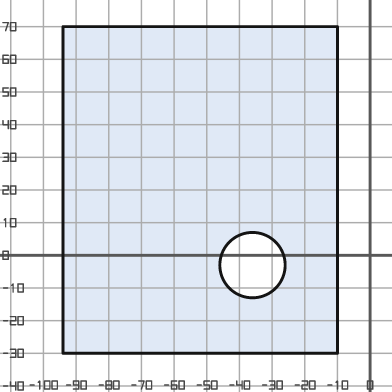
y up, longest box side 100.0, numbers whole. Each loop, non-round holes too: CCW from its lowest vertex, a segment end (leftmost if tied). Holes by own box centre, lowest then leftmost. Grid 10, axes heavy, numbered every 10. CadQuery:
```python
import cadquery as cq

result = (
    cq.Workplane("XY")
    .moveTo(-94.0, -30.0)
    .lineTo(-10.0, -30.0)
    .lineTo(-10.0, 70.0)
    .lineTo(-94.0, 70.0)
    .close()
    .moveTo(-36.0, -3.0)
    .circle(10.0)
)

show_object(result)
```